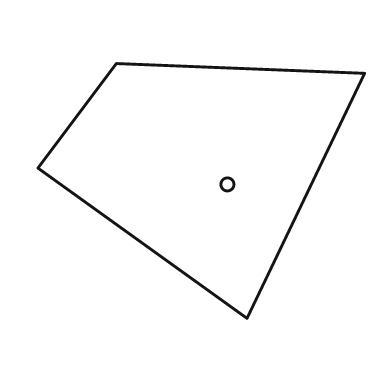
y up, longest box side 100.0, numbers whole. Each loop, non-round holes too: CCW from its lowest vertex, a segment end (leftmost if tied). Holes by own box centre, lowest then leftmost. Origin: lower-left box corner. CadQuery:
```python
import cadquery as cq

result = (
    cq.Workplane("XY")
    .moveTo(64.0, 0.0)
    .lineTo(100.0, 75.0)
    .lineTo(24.0, 78.0)
    .lineTo(0.0, 46.0)
    .close()
    .moveTo(58.0, 41.0)
    .circle(2.0)
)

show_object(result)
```